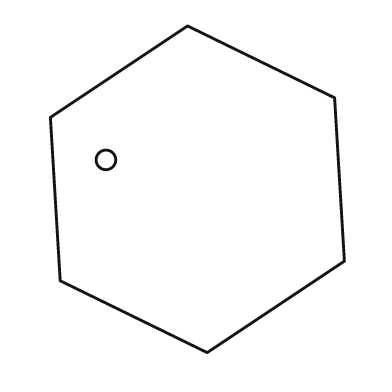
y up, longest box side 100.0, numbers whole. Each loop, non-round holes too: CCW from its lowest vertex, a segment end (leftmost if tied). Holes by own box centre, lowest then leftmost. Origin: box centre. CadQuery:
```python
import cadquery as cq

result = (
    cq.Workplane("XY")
    .moveTo(3.0, -50.0)
    .lineTo(45.0, -22.0)
    .lineTo(42.0, 28.0)
    .lineTo(-3.0, 50.0)
    .lineTo(-45.0, 22.0)
    .lineTo(-42.0, -28.0)
    .close()
    .moveTo(-28.0, 9.0)
    .circle(3.0)
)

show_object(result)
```